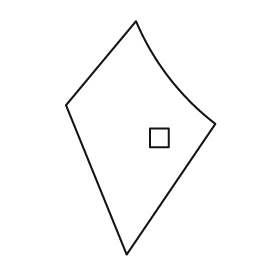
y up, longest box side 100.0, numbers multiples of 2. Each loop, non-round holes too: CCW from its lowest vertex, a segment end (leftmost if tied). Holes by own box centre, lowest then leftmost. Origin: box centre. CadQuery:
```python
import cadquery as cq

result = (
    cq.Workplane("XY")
    .moveTo(-6.0, -50.0)
    .lineTo(32.0, 6.0)
    .threePointArc((12.0, 26.0), (-2.0, 50.0))
    .lineTo(-32.0, 14.0)
    .close()
    .moveTo(4.0, -4.0)
    .lineTo(12.0, -4.0)
    .lineTo(12.0, 4.0)
    .lineTo(4.0, 4.0)
    .close()
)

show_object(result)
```